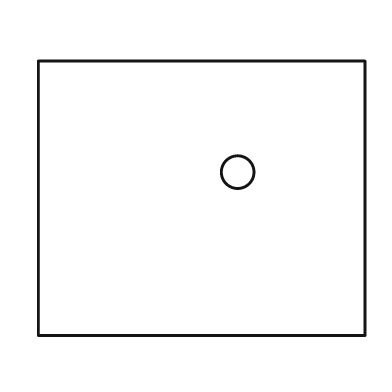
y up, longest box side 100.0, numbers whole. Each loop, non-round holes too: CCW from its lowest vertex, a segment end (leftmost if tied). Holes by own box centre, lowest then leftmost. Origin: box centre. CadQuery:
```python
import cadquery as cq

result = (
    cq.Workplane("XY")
    .moveTo(-50.0, -42.0)
    .lineTo(50.0, -42.0)
    .lineTo(50.0, 42.0)
    .lineTo(-50.0, 42.0)
    .close()
    .moveTo(11.0, 8.0)
    .circle(5.0)
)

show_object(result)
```